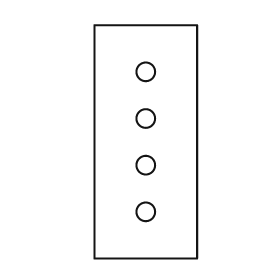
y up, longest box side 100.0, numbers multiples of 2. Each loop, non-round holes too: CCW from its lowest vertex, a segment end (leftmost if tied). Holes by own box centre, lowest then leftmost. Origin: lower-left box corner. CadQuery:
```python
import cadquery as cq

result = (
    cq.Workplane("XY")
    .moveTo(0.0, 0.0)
    .lineTo(44.0, 0.0)
    .lineTo(44.0, 100.0)
    .lineTo(0.0, 100.0)
    .close()
    .moveTo(22.0, 20.0)
    .circle(4.0)
    .moveTo(22.0, 40.0)
    .circle(4.0)
    .moveTo(22.0, 60.0)
    .circle(4.0)
    .moveTo(22.0, 80.0)
    .circle(4.0)
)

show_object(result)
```